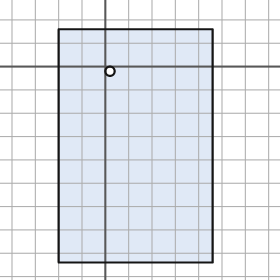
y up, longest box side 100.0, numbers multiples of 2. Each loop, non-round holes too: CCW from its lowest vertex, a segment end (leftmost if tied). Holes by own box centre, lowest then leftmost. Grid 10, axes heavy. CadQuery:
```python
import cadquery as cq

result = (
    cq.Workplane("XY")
    .moveTo(-20.0, -84.0)
    .lineTo(46.0, -84.0)
    .lineTo(46.0, 16.0)
    .lineTo(-20.0, 16.0)
    .close()
    .moveTo(2.0, -2.0)
    .circle(2.0)
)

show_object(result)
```